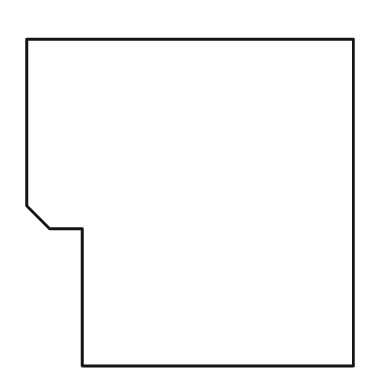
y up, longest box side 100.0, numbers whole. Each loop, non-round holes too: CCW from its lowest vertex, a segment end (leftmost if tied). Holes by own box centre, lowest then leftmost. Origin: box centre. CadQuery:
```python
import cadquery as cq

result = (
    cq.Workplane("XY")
    .moveTo(-33.0, -50.0)
    .lineTo(50.0, -50.0)
    .lineTo(50.0, 50.0)
    .lineTo(-50.0, 50.0)
    .lineTo(-50.0, -1.0)
    .lineTo(-43.0, -8.0)
    .lineTo(-33.0, -8.0)
    .close()
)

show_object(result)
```